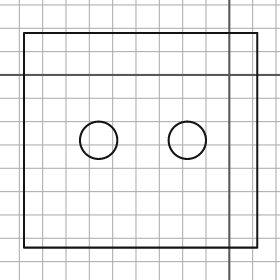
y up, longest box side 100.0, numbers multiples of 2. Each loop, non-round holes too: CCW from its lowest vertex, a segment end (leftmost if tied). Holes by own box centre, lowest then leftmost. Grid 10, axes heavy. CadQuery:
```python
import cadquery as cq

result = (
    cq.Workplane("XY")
    .moveTo(-88.0, -74.0)
    .lineTo(12.0, -74.0)
    .lineTo(12.0, 18.0)
    .lineTo(-88.0, 18.0)
    .close()
    .moveTo(-56.0, -28.0)
    .circle(8.0)
    .moveTo(-18.0, -28.0)
    .circle(8.0)
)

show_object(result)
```